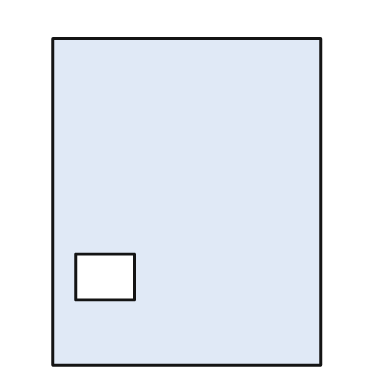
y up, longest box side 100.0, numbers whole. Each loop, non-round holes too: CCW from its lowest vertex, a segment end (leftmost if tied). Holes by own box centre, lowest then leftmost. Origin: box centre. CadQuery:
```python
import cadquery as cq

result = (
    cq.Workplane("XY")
    .moveTo(-41.0, -50.0)
    .lineTo(41.0, -50.0)
    .lineTo(41.0, 50.0)
    .lineTo(-41.0, 50.0)
    .close()
    .moveTo(-34.0, -30.0)
    .lineTo(-16.0, -30.0)
    .lineTo(-16.0, -16.0)
    .lineTo(-34.0, -16.0)
    .close()
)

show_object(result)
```